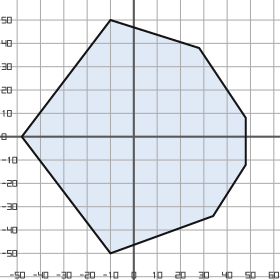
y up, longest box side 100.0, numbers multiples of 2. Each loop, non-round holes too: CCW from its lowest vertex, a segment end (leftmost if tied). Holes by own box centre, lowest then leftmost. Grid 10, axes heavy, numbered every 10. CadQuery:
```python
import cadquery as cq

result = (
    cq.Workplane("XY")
    .moveTo(-10.0, -50.0)
    .lineTo(34.0, -34.0)
    .lineTo(48.0, -12.0)
    .lineTo(48.0, 8.0)
    .lineTo(28.0, 38.0)
    .lineTo(-10.0, 50.0)
    .lineTo(-48.0, 0.0)
    .close()
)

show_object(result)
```